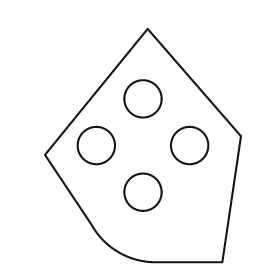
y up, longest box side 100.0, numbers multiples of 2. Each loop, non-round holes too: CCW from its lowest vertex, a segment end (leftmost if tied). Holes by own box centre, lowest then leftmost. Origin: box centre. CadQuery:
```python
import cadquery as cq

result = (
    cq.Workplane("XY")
    .moveTo(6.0, -50.0)
    .lineTo(34.0, -50.0)
    .lineTo(42.0, 4.0)
    .lineTo(2.0, 50.0)
    .lineTo(-42.0, -4.0)
    .lineTo(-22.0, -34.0)
    .threePointArc((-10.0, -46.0), (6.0, -50.0))
    .close()
    .moveTo(0.0, -20.0)
    .circle(8.0)
    .moveTo(-20.0, 0.0)
    .circle(8.0)
    .moveTo(20.0, 0.0)
    .circle(8.0)
    .moveTo(0.0, 20.0)
    .circle(8.0)
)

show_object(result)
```